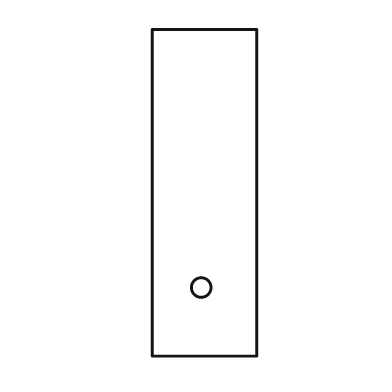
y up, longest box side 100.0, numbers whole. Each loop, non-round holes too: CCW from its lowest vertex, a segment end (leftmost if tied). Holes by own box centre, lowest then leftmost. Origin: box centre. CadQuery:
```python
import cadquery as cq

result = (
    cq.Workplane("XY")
    .moveTo(-16.0, -50.0)
    .lineTo(16.0, -50.0)
    .lineTo(16.0, 50.0)
    .lineTo(-16.0, 50.0)
    .close()
    .moveTo(-1.0, -29.0)
    .circle(3.0)
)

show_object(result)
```